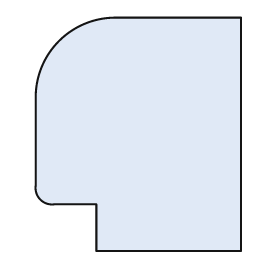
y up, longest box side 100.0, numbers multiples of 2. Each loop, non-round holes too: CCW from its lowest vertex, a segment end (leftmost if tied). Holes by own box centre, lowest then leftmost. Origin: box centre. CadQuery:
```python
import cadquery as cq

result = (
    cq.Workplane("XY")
    .moveTo(-18.0, -50.0)
    .lineTo(44.0, -50.0)
    .lineTo(44.0, 50.0)
    .lineTo(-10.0, 50.0)
    .threePointArc((-34.0, 40.0), (-44.0, 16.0))
    .lineTo(-44.0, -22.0)
    .threePointArc((-42.0, -28.0), (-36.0, -30.0))
    .lineTo(-18.0, -30.0)
    .close()
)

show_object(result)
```